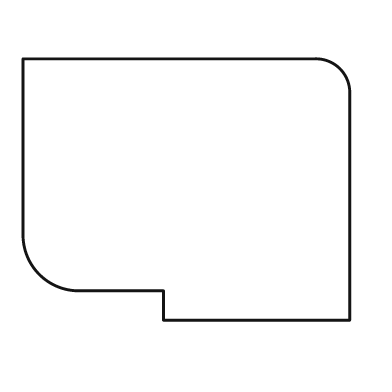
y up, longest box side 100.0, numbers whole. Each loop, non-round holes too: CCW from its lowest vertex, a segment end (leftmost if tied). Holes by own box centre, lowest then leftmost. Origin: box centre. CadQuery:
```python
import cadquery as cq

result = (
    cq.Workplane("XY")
    .moveTo(-7.0, -40.0)
    .lineTo(50.0, -40.0)
    .lineTo(50.0, 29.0)
    .threePointArc((47.0, 37.0), (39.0, 40.0))
    .lineTo(-50.0, 40.0)
    .lineTo(-50.0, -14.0)
    .threePointArc((-45.0, -26.0), (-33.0, -31.0))
    .lineTo(-7.0, -31.0)
    .close()
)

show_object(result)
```